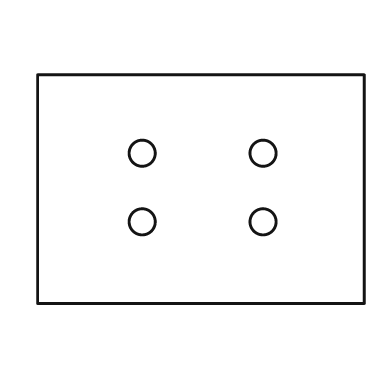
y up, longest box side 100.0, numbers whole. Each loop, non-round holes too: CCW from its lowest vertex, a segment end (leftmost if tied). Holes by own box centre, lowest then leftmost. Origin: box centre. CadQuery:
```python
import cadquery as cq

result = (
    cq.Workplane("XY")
    .moveTo(-50.0, -35.0)
    .lineTo(50.0, -35.0)
    .lineTo(50.0, 35.0)
    .lineTo(-50.0, 35.0)
    .close()
    .moveTo(-18.0, -10.0)
    .circle(4.0)
    .moveTo(19.0, -10.0)
    .circle(4.0)
    .moveTo(-18.0, 11.0)
    .circle(4.0)
    .moveTo(19.0, 11.0)
    .circle(4.0)
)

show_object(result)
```